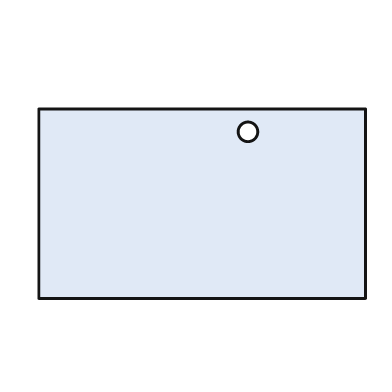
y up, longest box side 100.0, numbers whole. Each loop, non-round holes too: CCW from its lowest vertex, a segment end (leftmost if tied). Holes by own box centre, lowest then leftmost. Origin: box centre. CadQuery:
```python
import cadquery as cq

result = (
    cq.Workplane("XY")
    .moveTo(-50.0, -29.0)
    .lineTo(50.0, -29.0)
    .lineTo(50.0, 29.0)
    .lineTo(-50.0, 29.0)
    .close()
    .moveTo(14.0, 22.0)
    .circle(3.0)
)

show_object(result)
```